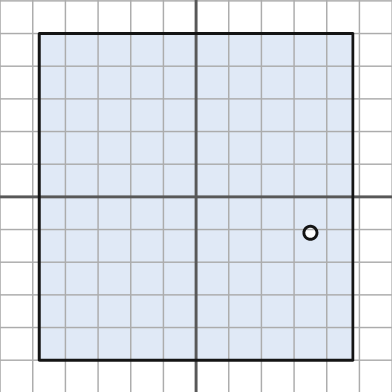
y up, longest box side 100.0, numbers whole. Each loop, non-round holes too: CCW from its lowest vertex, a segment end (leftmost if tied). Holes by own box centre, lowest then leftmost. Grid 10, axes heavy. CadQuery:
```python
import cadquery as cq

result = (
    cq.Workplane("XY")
    .moveTo(-48.0, -50.0)
    .lineTo(48.0, -50.0)
    .lineTo(48.0, 50.0)
    .lineTo(-48.0, 50.0)
    .close()
    .moveTo(35.0, -11.0)
    .circle(2.0)
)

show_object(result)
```